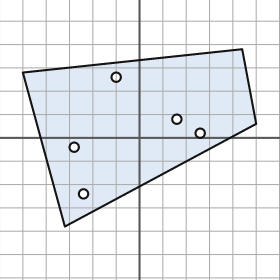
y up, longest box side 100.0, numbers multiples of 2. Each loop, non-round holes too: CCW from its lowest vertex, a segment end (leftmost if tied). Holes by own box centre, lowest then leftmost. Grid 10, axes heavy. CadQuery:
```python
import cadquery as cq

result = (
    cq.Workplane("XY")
    .moveTo(-32.0, -38.0)
    .lineTo(50.0, 6.0)
    .lineTo(44.0, 38.0)
    .lineTo(-50.0, 28.0)
    .close()
    .moveTo(-24.0, -24.0)
    .circle(2.0)
    .moveTo(-28.0, -4.0)
    .circle(2.0)
    .moveTo(26.0, 2.0)
    .circle(2.0)
    .moveTo(16.0, 8.0)
    .circle(2.0)
    .moveTo(-10.0, 26.0)
    .circle(2.0)
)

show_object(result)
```